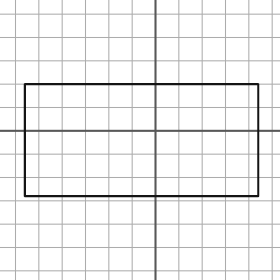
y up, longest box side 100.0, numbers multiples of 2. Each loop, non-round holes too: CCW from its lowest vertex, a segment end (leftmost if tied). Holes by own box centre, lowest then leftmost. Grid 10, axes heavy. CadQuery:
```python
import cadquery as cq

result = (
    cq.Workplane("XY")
    .moveTo(-56.0, -28.0)
    .lineTo(44.0, -28.0)
    .lineTo(44.0, 20.0)
    .lineTo(-56.0, 20.0)
    .close()
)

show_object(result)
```